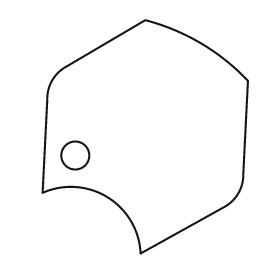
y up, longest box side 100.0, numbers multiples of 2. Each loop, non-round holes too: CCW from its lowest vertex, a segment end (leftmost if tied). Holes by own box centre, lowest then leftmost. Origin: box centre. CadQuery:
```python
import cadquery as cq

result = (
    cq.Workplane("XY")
    .moveTo(-2.0, -50.0)
    .lineTo(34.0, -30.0)
    .threePointArc((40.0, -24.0), (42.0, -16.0))
    .lineTo(44.0, 24.0)
    .threePointArc((24.0, 40.0), (0.0, 50.0))
    .lineTo(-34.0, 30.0)
    .threePointArc((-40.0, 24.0), (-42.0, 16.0))
    .lineTo(-44.0, -24.0)
    .threePointArc((-16.0, -26.0), (-2.0, -50.0))
    .close()
    .moveTo(-30.0, -8.0)
    .circle(6.0)
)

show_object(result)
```